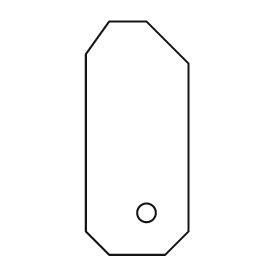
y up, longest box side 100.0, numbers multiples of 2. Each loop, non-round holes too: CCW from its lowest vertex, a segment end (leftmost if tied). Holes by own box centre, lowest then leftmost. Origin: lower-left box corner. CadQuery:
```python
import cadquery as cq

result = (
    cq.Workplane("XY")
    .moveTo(10.0, 0.0)
    .lineTo(34.0, 0.0)
    .lineTo(44.0, 10.0)
    .lineTo(44.0, 82.0)
    .lineTo(26.0, 100.0)
    .lineTo(10.0, 100.0)
    .lineTo(0.0, 86.0)
    .lineTo(0.0, 10.0)
    .close()
    .moveTo(26.0, 18.0)
    .circle(4.0)
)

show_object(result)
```